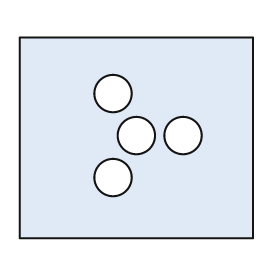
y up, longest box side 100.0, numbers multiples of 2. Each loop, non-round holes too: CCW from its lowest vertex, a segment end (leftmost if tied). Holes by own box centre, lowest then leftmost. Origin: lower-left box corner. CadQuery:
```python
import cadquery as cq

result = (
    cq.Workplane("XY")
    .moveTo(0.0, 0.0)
    .lineTo(100.0, 0.0)
    .lineTo(100.0, 86.0)
    .lineTo(0.0, 86.0)
    .close()
    .moveTo(40.0, 26.0)
    .circle(8.0)
    .moveTo(50.0, 44.0)
    .circle(8.0)
    .moveTo(70.0, 44.0)
    .circle(8.0)
    .moveTo(40.0, 62.0)
    .circle(8.0)
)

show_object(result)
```